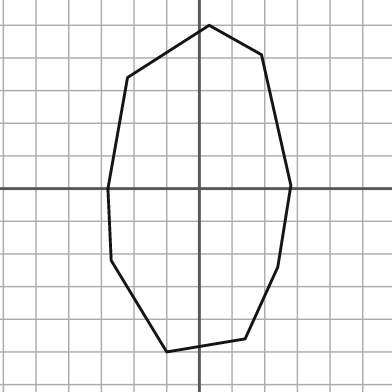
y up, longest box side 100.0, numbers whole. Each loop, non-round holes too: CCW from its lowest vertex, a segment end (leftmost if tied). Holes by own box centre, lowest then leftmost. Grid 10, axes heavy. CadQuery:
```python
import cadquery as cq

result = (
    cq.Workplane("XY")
    .moveTo(-10.0, -50.0)
    .lineTo(14.0, -46.0)
    .lineTo(24.0, -24.0)
    .lineTo(28.0, 1.0)
    .lineTo(19.0, 41.0)
    .lineTo(3.0, 50.0)
    .lineTo(-22.0, 34.0)
    .lineTo(-28.0, 0.0)
    .lineTo(-27.0, -22.0)
    .close()
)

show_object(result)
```